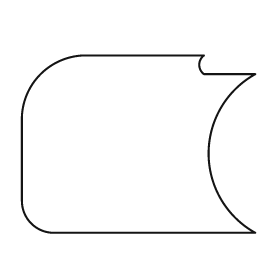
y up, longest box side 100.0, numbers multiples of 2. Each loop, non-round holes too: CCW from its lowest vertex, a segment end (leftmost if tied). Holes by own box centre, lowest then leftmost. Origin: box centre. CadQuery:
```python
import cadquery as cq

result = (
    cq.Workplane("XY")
    .moveTo(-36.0, -38.0)
    .lineTo(50.0, -38.0)
    .threePointArc((30.0, -4.0), (50.0, 30.0))
    .lineTo(28.0, 30.0)
    .threePointArc((26.0, 34.0), (28.0, 38.0))
    .lineTo(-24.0, 38.0)
    .threePointArc((-42.0, 30.0), (-50.0, 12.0))
    .lineTo(-50.0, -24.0)
    .threePointArc((-46.0, -34.0), (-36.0, -38.0))
    .close()
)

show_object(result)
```